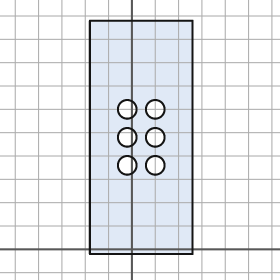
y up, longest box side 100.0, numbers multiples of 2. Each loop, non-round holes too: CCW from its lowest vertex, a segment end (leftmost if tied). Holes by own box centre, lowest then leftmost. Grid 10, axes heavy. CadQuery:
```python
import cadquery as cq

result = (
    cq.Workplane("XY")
    .moveTo(-18.0, -2.0)
    .lineTo(26.0, -2.0)
    .lineTo(26.0, 98.0)
    .lineTo(-18.0, 98.0)
    .close()
    .moveTo(-2.0, 36.0)
    .circle(4.0)
    .moveTo(10.0, 36.0)
    .circle(4.0)
    .moveTo(-2.0, 48.0)
    .circle(4.0)
    .moveTo(10.0, 48.0)
    .circle(4.0)
    .moveTo(-2.0, 60.0)
    .circle(4.0)
    .moveTo(10.0, 60.0)
    .circle(4.0)
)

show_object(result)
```